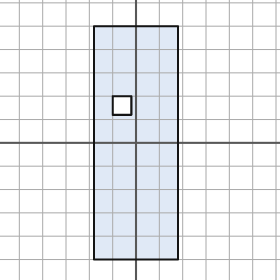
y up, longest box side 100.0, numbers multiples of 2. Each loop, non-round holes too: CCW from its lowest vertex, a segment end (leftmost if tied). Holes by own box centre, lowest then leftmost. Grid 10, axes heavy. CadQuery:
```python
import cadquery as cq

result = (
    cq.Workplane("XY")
    .moveTo(-18.0, -50.0)
    .lineTo(18.0, -50.0)
    .lineTo(18.0, 50.0)
    .lineTo(-18.0, 50.0)
    .close()
    .moveTo(-10.0, 12.0)
    .lineTo(-2.0, 12.0)
    .lineTo(-2.0, 20.0)
    .lineTo(-10.0, 20.0)
    .close()
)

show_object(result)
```